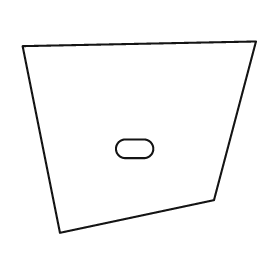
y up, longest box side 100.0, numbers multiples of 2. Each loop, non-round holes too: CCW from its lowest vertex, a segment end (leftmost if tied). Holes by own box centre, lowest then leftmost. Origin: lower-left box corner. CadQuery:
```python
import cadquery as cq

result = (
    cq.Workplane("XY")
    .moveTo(16.0, 0.0)
    .lineTo(82.0, 14.0)
    .lineTo(100.0, 82.0)
    .lineTo(0.0, 80.0)
    .close()
    .moveTo(44.0, 32.0)
    .lineTo(52.0, 32.0)
    .threePointArc((56.0, 36.0), (52.0, 40.0))
    .lineTo(44.0, 40.0)
    .threePointArc((40.0, 36.0), (44.0, 32.0))
    .close()
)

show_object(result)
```